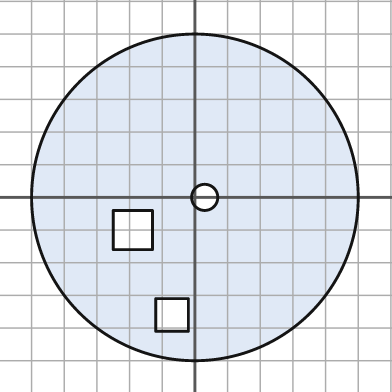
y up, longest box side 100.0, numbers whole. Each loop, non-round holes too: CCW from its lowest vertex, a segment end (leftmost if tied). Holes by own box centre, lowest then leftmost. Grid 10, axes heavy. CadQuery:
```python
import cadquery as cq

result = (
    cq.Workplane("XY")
    .moveTo(0.0, 0.0)
    .circle(50.0)
    .moveTo(-12.0, -41.0)
    .lineTo(-2.0, -41.0)
    .lineTo(-2.0, -31.0)
    .lineTo(-12.0, -31.0)
    .close()
    .moveTo(-25.0, -16.0)
    .lineTo(-13.0, -16.0)
    .lineTo(-13.0, -4.0)
    .lineTo(-25.0, -4.0)
    .close()
    .moveTo(3.0, 0.0)
    .circle(4.0)
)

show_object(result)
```